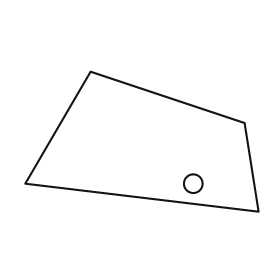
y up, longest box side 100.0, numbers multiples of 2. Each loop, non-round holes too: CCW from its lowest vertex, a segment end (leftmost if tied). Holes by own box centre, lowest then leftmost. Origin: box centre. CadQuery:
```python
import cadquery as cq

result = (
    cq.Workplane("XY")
    .moveTo(50.0, -30.0)
    .lineTo(44.0, 8.0)
    .lineTo(-22.0, 30.0)
    .lineTo(-50.0, -18.0)
    .close()
    .moveTo(22.0, -18.0)
    .circle(4.0)
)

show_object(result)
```